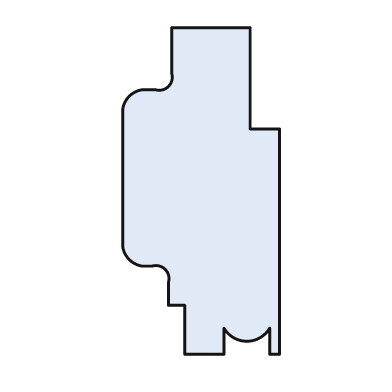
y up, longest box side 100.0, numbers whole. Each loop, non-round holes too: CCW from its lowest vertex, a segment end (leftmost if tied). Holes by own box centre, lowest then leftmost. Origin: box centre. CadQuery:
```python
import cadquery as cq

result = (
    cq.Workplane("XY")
    .moveTo(-5.0, -50.0)
    .lineTo(7.0, -50.0)
    .lineTo(7.0, -42.0)
    .threePointArc((14.0, -46.0), (21.0, -42.0))
    .lineTo(21.0, -50.0)
    .lineTo(24.0, -50.0)
    .lineTo(24.0, 19.0)
    .lineTo(15.0, 19.0)
    .lineTo(15.0, 50.0)
    .lineTo(-9.0, 50.0)
    .lineTo(-9.0, 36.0)
    .threePointArc((-10.0, 32.0), (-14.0, 31.0))
    .lineTo(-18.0, 31.0)
    .threePointArc((-22.0, 29.0), (-24.0, 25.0))
    .lineTo(-24.0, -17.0)
    .threePointArc((-22.0, -21.0), (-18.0, -23.0))
    .lineTo(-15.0, -23.0)
    .threePointArc((-11.0, -24.0), (-10.0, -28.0))
    .lineTo(-10.0, -35.0)
    .lineTo(-5.0, -35.0)
    .close()
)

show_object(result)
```